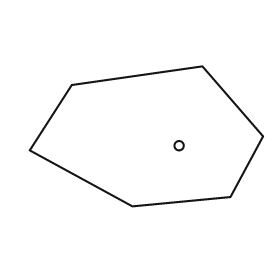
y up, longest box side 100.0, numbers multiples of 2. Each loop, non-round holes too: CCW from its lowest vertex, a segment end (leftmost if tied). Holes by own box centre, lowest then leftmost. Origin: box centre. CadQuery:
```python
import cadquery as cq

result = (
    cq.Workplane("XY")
    .moveTo(-6.0, -30.0)
    .lineTo(36.0, -26.0)
    .lineTo(50.0, 0.0)
    .lineTo(24.0, 30.0)
    .lineTo(-32.0, 22.0)
    .lineTo(-50.0, -6.0)
    .close()
    .moveTo(14.0, -4.0)
    .circle(2.0)
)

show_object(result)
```